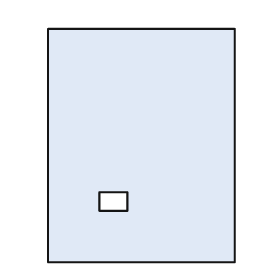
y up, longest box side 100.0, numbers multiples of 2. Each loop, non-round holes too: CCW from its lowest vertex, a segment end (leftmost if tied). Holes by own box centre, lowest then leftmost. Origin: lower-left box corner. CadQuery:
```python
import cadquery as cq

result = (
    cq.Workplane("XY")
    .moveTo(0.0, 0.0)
    .lineTo(80.0, 0.0)
    .lineTo(80.0, 100.0)
    .lineTo(0.0, 100.0)
    .close()
    .moveTo(22.0, 22.0)
    .lineTo(34.0, 22.0)
    .lineTo(34.0, 30.0)
    .lineTo(22.0, 30.0)
    .close()
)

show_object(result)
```